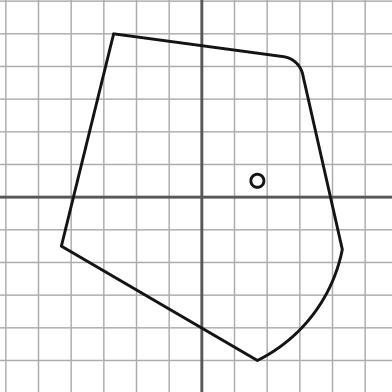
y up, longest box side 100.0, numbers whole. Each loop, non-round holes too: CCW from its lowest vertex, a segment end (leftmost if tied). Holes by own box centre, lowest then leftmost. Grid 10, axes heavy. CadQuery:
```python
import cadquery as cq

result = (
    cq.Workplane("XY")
    .moveTo(17.0, -50.0)
    .threePointArc((34.0, -36.0), (43.0, -16.0))
    .lineTo(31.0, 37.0)
    .threePointArc((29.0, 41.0), (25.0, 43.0))
    .lineTo(-27.0, 50.0)
    .lineTo(-43.0, -15.0)
    .close()
    .moveTo(17.0, 5.0)
    .circle(2.0)
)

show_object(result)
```